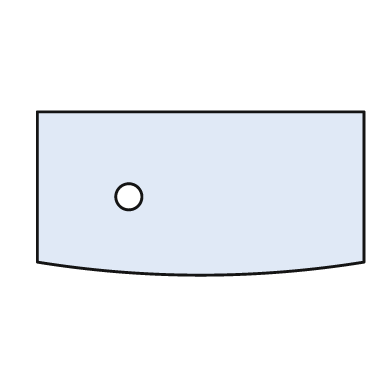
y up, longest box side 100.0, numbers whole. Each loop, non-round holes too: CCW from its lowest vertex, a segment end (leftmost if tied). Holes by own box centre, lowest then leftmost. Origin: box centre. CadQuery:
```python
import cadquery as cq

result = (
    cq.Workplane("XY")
    .moveTo(-50.0, -21.0)
    .threePointArc((0.0, -25.0), (50.0, -21.0))
    .lineTo(50.0, 25.0)
    .lineTo(-50.0, 25.0)
    .close()
    .moveTo(-22.0, -1.0)
    .circle(4.0)
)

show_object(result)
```